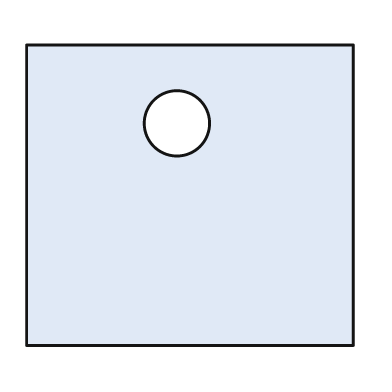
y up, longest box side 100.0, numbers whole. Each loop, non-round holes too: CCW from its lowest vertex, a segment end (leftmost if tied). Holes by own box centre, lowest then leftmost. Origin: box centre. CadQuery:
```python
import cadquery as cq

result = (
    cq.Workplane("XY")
    .moveTo(-50.0, -46.0)
    .lineTo(50.0, -46.0)
    .lineTo(50.0, 46.0)
    .lineTo(-50.0, 46.0)
    .close()
    .moveTo(-4.0, 22.0)
    .circle(10.0)
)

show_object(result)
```